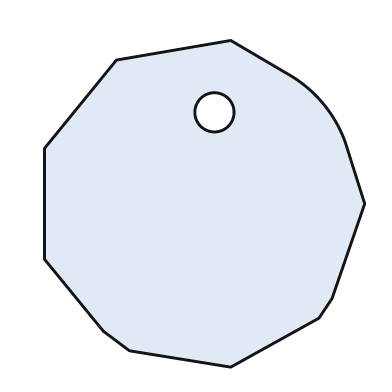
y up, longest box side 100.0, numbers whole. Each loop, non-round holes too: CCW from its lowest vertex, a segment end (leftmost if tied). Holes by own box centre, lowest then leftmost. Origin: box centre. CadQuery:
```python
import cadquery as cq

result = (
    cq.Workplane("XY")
    .moveTo(8.0, -50.0)
    .lineTo(35.0, -35.0)
    .lineTo(39.0, -29.0)
    .lineTo(49.0, 0.0)
    .lineTo(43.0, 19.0)
    .threePointArc((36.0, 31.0), (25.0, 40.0))
    .lineTo(8.0, 50.0)
    .lineTo(-27.0, 44.0)
    .lineTo(-49.0, 17.0)
    .lineTo(-49.0, -17.0)
    .lineTo(-31.0, -39.0)
    .lineTo(-23.0, -45.0)
    .close()
    .moveTo(3.0, 28.0)
    .circle(6.0)
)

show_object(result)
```